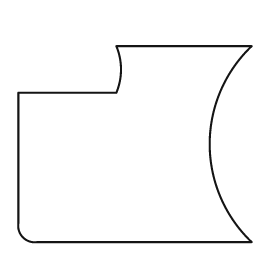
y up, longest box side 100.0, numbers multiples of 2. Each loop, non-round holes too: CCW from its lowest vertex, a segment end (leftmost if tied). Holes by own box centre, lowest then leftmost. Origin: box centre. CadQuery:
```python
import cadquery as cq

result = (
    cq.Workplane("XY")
    .moveTo(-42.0, -42.0)
    .lineTo(50.0, -42.0)
    .threePointArc((32.0, 0.0), (50.0, 42.0))
    .lineTo(-8.0, 42.0)
    .threePointArc((-6.0, 32.0), (-8.0, 22.0))
    .lineTo(-50.0, 22.0)
    .lineTo(-50.0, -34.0)
    .threePointArc((-48.0, -40.0), (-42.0, -42.0))
    .close()
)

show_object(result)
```